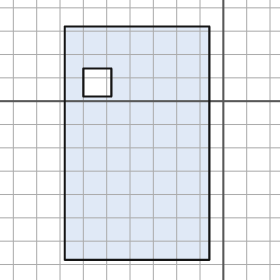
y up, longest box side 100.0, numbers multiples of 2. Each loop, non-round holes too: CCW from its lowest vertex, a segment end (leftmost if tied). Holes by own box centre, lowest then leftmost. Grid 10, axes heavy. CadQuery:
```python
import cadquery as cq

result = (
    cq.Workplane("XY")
    .moveTo(-68.0, -68.0)
    .lineTo(-6.0, -68.0)
    .lineTo(-6.0, 32.0)
    .lineTo(-68.0, 32.0)
    .close()
    .moveTo(-60.0, 2.0)
    .lineTo(-48.0, 2.0)
    .lineTo(-48.0, 14.0)
    .lineTo(-60.0, 14.0)
    .close()
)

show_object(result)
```